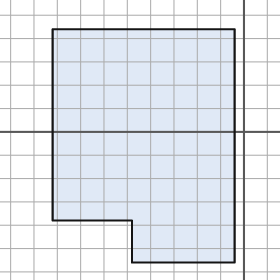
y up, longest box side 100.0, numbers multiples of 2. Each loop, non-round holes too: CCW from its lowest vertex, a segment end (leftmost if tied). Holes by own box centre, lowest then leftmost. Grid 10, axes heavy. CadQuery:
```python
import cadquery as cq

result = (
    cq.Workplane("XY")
    .moveTo(-48.0, -56.0)
    .lineTo(-4.0, -56.0)
    .lineTo(-4.0, 44.0)
    .lineTo(-82.0, 44.0)
    .lineTo(-82.0, -38.0)
    .lineTo(-48.0, -38.0)
    .close()
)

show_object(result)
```